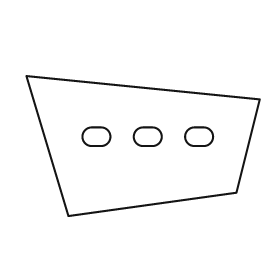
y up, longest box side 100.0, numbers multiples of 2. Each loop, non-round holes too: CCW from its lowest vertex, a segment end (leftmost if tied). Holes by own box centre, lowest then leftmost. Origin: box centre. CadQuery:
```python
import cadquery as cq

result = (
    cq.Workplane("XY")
    .moveTo(-32.0, -30.0)
    .lineTo(40.0, -20.0)
    .lineTo(50.0, 20.0)
    .lineTo(-50.0, 30.0)
    .close()
    .moveTo(-22.0, 0.0)
    .lineTo(-18.0, 0.0)
    .threePointArc((-14.0, 4.0), (-18.0, 8.0))
    .lineTo(-22.0, 8.0)
    .threePointArc((-26.0, 4.0), (-22.0, 0.0))
    .close()
    .moveTo(0.0, 0.0)
    .lineTo(4.0, 0.0)
    .threePointArc((8.0, 4.0), (4.0, 8.0))
    .lineTo(0.0, 8.0)
    .threePointArc((-4.0, 4.0), (0.0, 0.0))
    .close()
    .moveTo(22.0, 0.0)
    .lineTo(26.0, 0.0)
    .threePointArc((30.0, 4.0), (26.0, 8.0))
    .lineTo(22.0, 8.0)
    .threePointArc((18.0, 4.0), (22.0, 0.0))
    .close()
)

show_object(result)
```